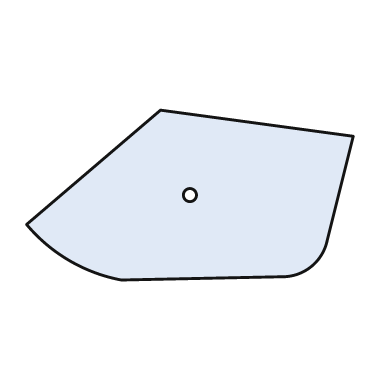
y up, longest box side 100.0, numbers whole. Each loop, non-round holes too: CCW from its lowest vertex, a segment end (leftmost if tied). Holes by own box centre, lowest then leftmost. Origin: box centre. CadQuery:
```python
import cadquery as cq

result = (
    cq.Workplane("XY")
    .moveTo(-21.0, -26.0)
    .lineTo(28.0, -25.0)
    .threePointArc((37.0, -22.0), (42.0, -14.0))
    .lineTo(50.0, 18.0)
    .lineTo(-9.0, 26.0)
    .lineTo(-50.0, -9.0)
    .threePointArc((-37.0, -20.0), (-21.0, -26.0))
    .close()
    .moveTo(0.0, 0.0)
    .circle(2.0)
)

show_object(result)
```